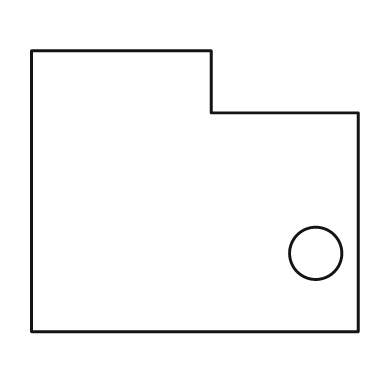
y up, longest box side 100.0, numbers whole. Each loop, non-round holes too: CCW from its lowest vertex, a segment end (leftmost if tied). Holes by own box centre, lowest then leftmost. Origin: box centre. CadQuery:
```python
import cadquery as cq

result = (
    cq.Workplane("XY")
    .moveTo(-50.0, -43.0)
    .lineTo(50.0, -43.0)
    .lineTo(50.0, 24.0)
    .lineTo(5.0, 24.0)
    .lineTo(5.0, 43.0)
    .lineTo(-50.0, 43.0)
    .close()
    .moveTo(37.0, -19.0)
    .circle(8.0)
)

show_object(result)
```